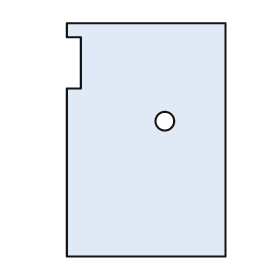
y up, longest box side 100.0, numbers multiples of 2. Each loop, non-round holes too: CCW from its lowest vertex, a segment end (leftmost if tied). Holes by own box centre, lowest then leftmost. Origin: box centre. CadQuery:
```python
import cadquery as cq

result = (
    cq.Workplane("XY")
    .moveTo(-34.0, -50.0)
    .lineTo(34.0, -50.0)
    .lineTo(34.0, 50.0)
    .lineTo(-34.0, 50.0)
    .lineTo(-34.0, 44.0)
    .lineTo(-28.0, 44.0)
    .lineTo(-28.0, 22.0)
    .lineTo(-34.0, 22.0)
    .close()
    .moveTo(8.0, 8.0)
    .circle(4.0)
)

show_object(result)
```